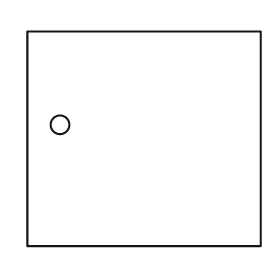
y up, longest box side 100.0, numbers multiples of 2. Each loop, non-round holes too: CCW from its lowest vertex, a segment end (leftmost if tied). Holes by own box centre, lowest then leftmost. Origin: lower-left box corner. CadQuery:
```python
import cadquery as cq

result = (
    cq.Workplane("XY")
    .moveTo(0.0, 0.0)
    .lineTo(100.0, 0.0)
    .lineTo(100.0, 92.0)
    .lineTo(0.0, 92.0)
    .close()
    .moveTo(14.0, 52.0)
    .circle(4.0)
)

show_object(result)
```